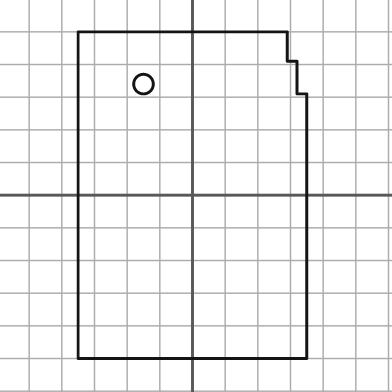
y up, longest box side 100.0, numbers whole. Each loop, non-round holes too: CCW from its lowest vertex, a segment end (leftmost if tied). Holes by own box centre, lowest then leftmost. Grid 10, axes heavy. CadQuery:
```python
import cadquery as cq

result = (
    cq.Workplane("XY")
    .moveTo(-35.0, -50.0)
    .lineTo(35.0, -50.0)
    .lineTo(35.0, 31.0)
    .lineTo(32.0, 31.0)
    .lineTo(32.0, 41.0)
    .lineTo(29.0, 41.0)
    .lineTo(29.0, 50.0)
    .lineTo(-35.0, 50.0)
    .close()
    .moveTo(-15.0, 34.0)
    .circle(3.0)
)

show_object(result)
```